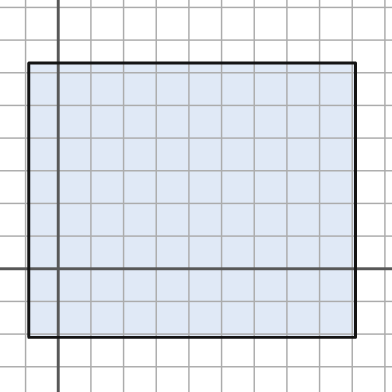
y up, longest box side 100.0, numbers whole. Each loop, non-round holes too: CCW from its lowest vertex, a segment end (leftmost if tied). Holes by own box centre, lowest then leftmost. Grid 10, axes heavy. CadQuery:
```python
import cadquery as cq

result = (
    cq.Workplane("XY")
    .moveTo(-9.0, -21.0)
    .lineTo(91.0, -21.0)
    .lineTo(91.0, 63.0)
    .lineTo(-9.0, 63.0)
    .close()
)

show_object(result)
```